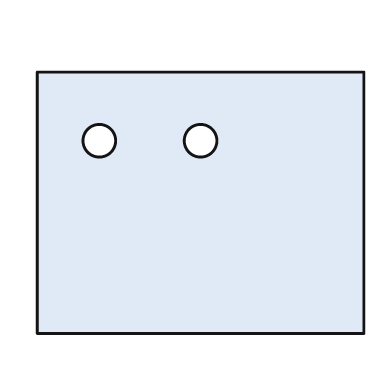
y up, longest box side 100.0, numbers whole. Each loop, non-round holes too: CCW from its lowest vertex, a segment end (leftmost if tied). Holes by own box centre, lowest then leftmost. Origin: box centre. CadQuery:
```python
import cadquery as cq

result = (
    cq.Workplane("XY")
    .moveTo(-50.0, -40.0)
    .lineTo(50.0, -40.0)
    .lineTo(50.0, 40.0)
    .lineTo(-50.0, 40.0)
    .close()
    .moveTo(-31.0, 19.0)
    .circle(5.0)
    .moveTo(0.0, 19.0)
    .circle(5.0)
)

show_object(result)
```